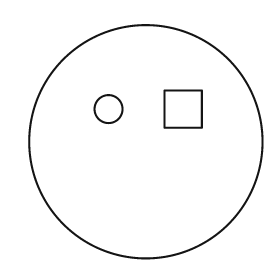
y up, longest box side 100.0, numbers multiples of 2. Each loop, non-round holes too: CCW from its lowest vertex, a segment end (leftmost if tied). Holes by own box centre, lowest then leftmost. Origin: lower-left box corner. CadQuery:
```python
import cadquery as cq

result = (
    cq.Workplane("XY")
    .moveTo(50.0, 50.0)
    .circle(50.0)
    .moveTo(34.0, 64.0)
    .circle(6.0)
    .moveTo(58.0, 56.0)
    .lineTo(74.0, 56.0)
    .lineTo(74.0, 72.0)
    .lineTo(58.0, 72.0)
    .close()
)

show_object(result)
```